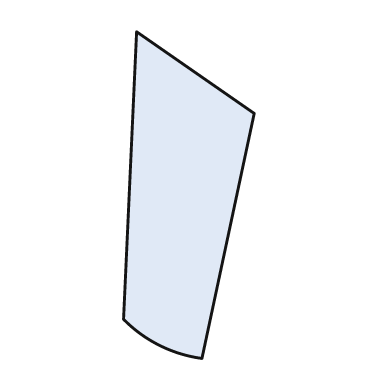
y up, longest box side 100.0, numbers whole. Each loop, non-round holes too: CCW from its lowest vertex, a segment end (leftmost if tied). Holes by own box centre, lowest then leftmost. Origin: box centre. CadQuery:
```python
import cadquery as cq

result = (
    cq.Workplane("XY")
    .moveTo(4.0, -50.0)
    .lineTo(20.0, 25.0)
    .lineTo(-16.0, 50.0)
    .lineTo(-20.0, -38.0)
    .threePointArc((-9.0, -46.0), (4.0, -50.0))
    .close()
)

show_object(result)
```